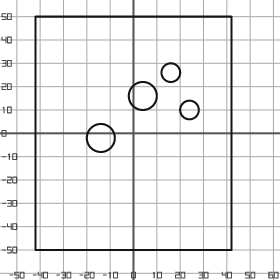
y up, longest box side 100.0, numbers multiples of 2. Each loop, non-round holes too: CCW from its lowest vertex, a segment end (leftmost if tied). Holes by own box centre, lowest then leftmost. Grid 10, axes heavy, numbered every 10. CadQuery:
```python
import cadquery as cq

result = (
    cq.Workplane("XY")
    .moveTo(-42.0, -50.0)
    .lineTo(42.0, -50.0)
    .lineTo(42.0, 50.0)
    .lineTo(-42.0, 50.0)
    .close()
    .moveTo(-14.0, -2.0)
    .circle(6.0)
    .moveTo(24.0, 10.0)
    .circle(4.0)
    .moveTo(4.0, 16.0)
    .circle(6.0)
    .moveTo(16.0, 26.0)
    .circle(4.0)
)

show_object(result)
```